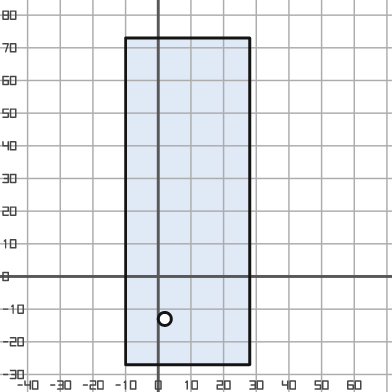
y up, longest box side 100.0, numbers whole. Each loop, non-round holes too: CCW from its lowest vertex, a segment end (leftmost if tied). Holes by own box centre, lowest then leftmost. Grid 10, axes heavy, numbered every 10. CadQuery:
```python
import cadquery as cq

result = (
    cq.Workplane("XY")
    .moveTo(-10.0, -27.0)
    .lineTo(28.0, -27.0)
    .lineTo(28.0, 73.0)
    .lineTo(-10.0, 73.0)
    .close()
    .moveTo(2.0, -13.0)
    .circle(2.0)
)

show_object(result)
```